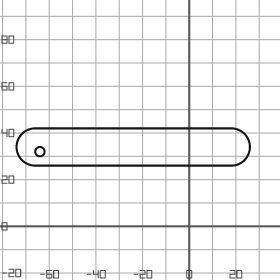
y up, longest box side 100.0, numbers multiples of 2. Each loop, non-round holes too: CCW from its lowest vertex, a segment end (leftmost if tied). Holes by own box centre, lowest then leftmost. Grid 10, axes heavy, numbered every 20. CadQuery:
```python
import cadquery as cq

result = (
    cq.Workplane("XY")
    .moveTo(-66.0, 26.0)
    .lineTo(18.0, 26.0)
    .threePointArc((26.0, 34.0), (18.0, 42.0))
    .lineTo(-66.0, 42.0)
    .threePointArc((-74.0, 34.0), (-66.0, 26.0))
    .close()
    .moveTo(-64.0, 32.0)
    .circle(2.0)
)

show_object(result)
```